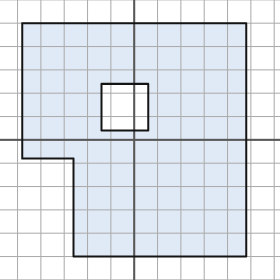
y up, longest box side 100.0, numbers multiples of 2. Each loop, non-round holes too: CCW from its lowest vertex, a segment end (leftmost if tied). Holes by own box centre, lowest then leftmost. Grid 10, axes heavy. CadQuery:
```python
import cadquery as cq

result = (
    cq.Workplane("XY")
    .moveTo(-26.0, -50.0)
    .lineTo(48.0, -50.0)
    .lineTo(48.0, 50.0)
    .lineTo(-48.0, 50.0)
    .lineTo(-48.0, -8.0)
    .lineTo(-26.0, -8.0)
    .close()
    .moveTo(-14.0, 4.0)
    .lineTo(6.0, 4.0)
    .lineTo(6.0, 24.0)
    .lineTo(-14.0, 24.0)
    .close()
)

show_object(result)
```